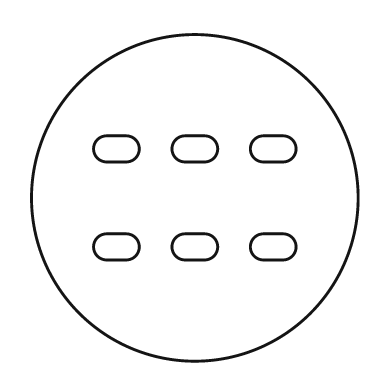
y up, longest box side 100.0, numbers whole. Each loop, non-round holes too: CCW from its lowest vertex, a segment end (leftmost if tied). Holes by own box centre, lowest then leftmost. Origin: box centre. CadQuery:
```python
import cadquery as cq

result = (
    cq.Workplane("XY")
    .moveTo(0.0, 0.0)
    .circle(50.0)
    .moveTo(-27.0, -19.0)
    .lineTo(-21.0, -19.0)
    .threePointArc((-17.0, -15.0), (-21.0, -11.0))
    .lineTo(-27.0, -11.0)
    .threePointArc((-31.0, -15.0), (-27.0, -19.0))
    .close()
    .moveTo(-3.0, -19.0)
    .lineTo(3.0, -19.0)
    .threePointArc((7.0, -15.0), (3.0, -11.0))
    .lineTo(-3.0, -11.0)
    .threePointArc((-7.0, -15.0), (-3.0, -19.0))
    .close()
    .moveTo(21.0, -19.0)
    .lineTo(27.0, -19.0)
    .threePointArc((31.0, -15.0), (27.0, -11.0))
    .lineTo(21.0, -11.0)
    .threePointArc((17.0, -15.0), (21.0, -19.0))
    .close()
    .moveTo(-27.0, 11.0)
    .lineTo(-21.0, 11.0)
    .threePointArc((-17.0, 15.0), (-21.0, 19.0))
    .lineTo(-27.0, 19.0)
    .threePointArc((-31.0, 15.0), (-27.0, 11.0))
    .close()
    .moveTo(-3.0, 11.0)
    .lineTo(3.0, 11.0)
    .threePointArc((7.0, 15.0), (3.0, 19.0))
    .lineTo(-3.0, 19.0)
    .threePointArc((-7.0, 15.0), (-3.0, 11.0))
    .close()
    .moveTo(21.0, 11.0)
    .lineTo(27.0, 11.0)
    .threePointArc((31.0, 15.0), (27.0, 19.0))
    .lineTo(21.0, 19.0)
    .threePointArc((17.0, 15.0), (21.0, 11.0))
    .close()
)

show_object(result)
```